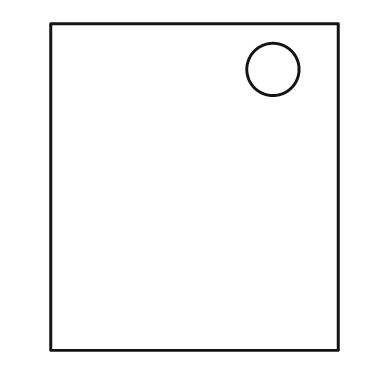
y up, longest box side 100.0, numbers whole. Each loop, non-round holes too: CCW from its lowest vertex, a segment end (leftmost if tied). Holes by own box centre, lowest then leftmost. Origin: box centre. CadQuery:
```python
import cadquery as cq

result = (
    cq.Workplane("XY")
    .moveTo(-44.0, -50.0)
    .lineTo(44.0, -50.0)
    .lineTo(44.0, 50.0)
    .lineTo(-44.0, 50.0)
    .close()
    .moveTo(24.0, 36.0)
    .circle(8.0)
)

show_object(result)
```